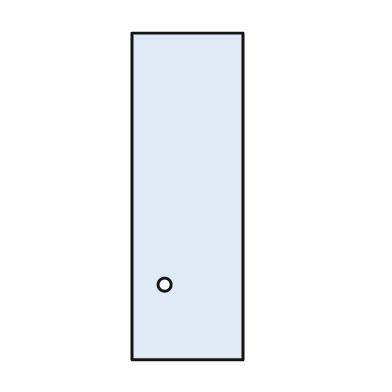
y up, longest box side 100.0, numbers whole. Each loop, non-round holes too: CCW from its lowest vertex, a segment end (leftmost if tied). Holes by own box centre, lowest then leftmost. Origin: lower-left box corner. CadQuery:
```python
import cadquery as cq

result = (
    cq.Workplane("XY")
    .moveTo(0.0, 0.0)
    .lineTo(34.0, 0.0)
    .lineTo(34.0, 100.0)
    .lineTo(0.0, 100.0)
    .close()
    .moveTo(10.0, 23.0)
    .circle(2.0)
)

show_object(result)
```